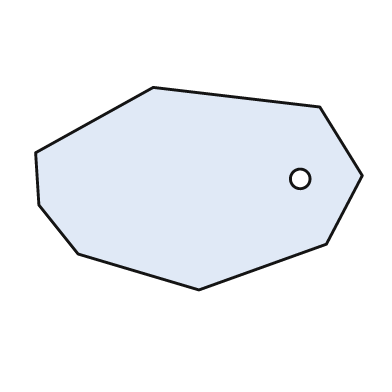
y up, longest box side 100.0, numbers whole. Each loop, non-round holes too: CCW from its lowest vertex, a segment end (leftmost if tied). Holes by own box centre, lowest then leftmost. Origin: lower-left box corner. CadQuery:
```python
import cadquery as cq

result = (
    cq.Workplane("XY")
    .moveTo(50.0, 0.0)
    .lineTo(89.0, 14.0)
    .lineTo(100.0, 35.0)
    .lineTo(87.0, 56.0)
    .lineTo(36.0, 62.0)
    .lineTo(0.0, 42.0)
    .lineTo(1.0, 26.0)
    .lineTo(13.0, 11.0)
    .close()
    .moveTo(81.0, 34.0)
    .circle(3.0)
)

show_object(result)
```